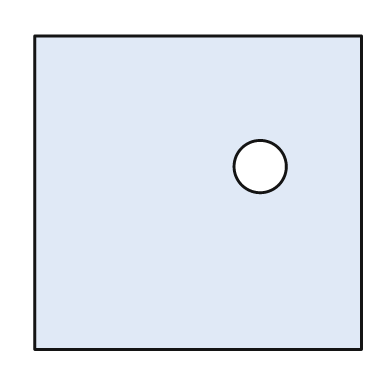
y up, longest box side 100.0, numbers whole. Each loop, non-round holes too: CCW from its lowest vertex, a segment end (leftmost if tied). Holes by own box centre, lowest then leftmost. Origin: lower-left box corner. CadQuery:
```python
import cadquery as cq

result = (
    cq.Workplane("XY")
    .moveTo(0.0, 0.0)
    .lineTo(100.0, 0.0)
    .lineTo(100.0, 96.0)
    .lineTo(0.0, 96.0)
    .close()
    .moveTo(69.0, 56.0)
    .circle(8.0)
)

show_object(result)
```